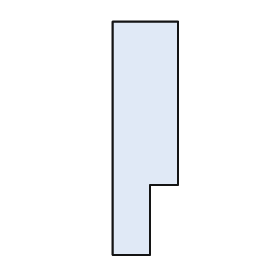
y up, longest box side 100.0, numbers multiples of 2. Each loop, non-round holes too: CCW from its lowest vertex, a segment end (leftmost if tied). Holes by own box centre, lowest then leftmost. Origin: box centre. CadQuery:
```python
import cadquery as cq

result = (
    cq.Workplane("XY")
    .moveTo(-14.0, -50.0)
    .lineTo(2.0, -50.0)
    .lineTo(2.0, -20.0)
    .lineTo(14.0, -20.0)
    .lineTo(14.0, 50.0)
    .lineTo(-14.0, 50.0)
    .close()
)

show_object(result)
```